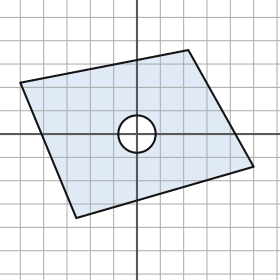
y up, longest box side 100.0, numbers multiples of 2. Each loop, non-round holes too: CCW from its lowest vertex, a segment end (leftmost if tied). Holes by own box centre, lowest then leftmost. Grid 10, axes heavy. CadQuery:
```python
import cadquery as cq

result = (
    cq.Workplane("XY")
    .moveTo(-26.0, -36.0)
    .lineTo(50.0, -14.0)
    .lineTo(22.0, 36.0)
    .lineTo(-50.0, 22.0)
    .close()
    .moveTo(0.0, 0.0)
    .circle(8.0)
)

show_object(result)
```